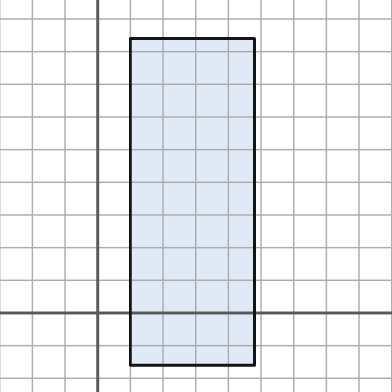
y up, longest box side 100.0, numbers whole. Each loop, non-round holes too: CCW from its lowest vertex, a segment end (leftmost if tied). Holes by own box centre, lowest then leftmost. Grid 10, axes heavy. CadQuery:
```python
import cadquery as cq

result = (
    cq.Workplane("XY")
    .moveTo(10.0, -16.0)
    .lineTo(48.0, -16.0)
    .lineTo(48.0, 84.0)
    .lineTo(10.0, 84.0)
    .close()
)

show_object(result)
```